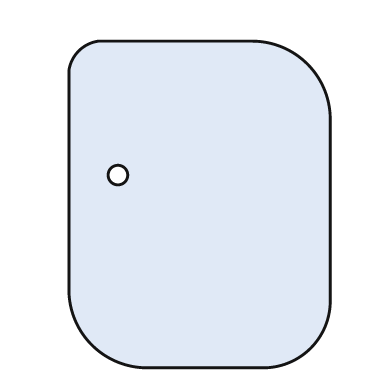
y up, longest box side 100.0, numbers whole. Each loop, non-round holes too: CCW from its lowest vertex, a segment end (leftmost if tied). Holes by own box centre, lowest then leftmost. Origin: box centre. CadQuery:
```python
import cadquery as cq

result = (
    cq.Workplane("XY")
    .moveTo(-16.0, -50.0)
    .lineTo(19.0, -50.0)
    .threePointArc((34.0, -44.0), (40.0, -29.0))
    .lineTo(40.0, 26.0)
    .threePointArc((33.0, 43.0), (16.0, 50.0))
    .lineTo(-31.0, 50.0)
    .threePointArc((-37.0, 47.0), (-40.0, 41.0))
    .lineTo(-40.0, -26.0)
    .threePointArc((-33.0, -43.0), (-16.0, -50.0))
    .close()
    .moveTo(-25.0, 9.0)
    .circle(3.0)
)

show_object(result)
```